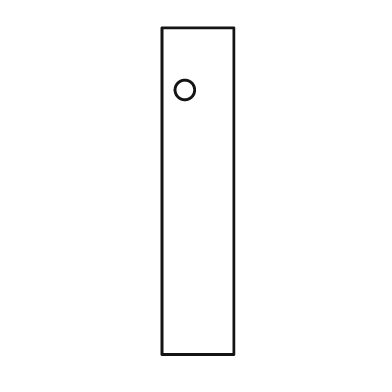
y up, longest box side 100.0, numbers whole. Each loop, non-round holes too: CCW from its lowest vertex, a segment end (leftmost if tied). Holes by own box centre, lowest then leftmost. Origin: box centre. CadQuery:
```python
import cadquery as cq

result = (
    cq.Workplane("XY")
    .moveTo(-11.0, -50.0)
    .lineTo(11.0, -50.0)
    .lineTo(11.0, 50.0)
    .lineTo(-11.0, 50.0)
    .close()
    .moveTo(-4.0, 31.0)
    .circle(3.0)
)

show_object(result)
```